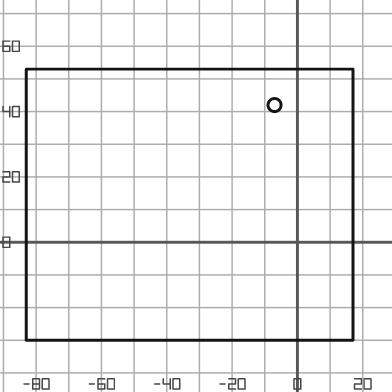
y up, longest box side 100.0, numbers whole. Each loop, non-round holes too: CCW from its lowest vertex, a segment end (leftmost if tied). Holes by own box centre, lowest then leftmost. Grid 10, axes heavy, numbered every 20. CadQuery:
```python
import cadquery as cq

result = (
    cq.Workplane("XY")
    .moveTo(-83.0, -30.0)
    .lineTo(17.0, -30.0)
    .lineTo(17.0, 53.0)
    .lineTo(-83.0, 53.0)
    .close()
    .moveTo(-7.0, 42.0)
    .circle(2.0)
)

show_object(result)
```